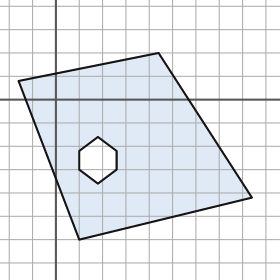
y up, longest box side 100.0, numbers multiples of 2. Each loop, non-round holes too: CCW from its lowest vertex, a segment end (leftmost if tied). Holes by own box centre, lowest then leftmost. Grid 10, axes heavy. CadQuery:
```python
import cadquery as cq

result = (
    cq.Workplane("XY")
    .moveTo(10.0, -60.0)
    .lineTo(84.0, -42.0)
    .lineTo(44.0, 20.0)
    .lineTo(-16.0, 8.0)
    .close()
    .moveTo(18.0, -36.0)
    .lineTo(26.0, -30.0)
    .lineTo(26.0, -22.0)
    .lineTo(18.0, -16.0)
    .lineTo(10.0, -22.0)
    .lineTo(10.0, -30.0)
    .close()
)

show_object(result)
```